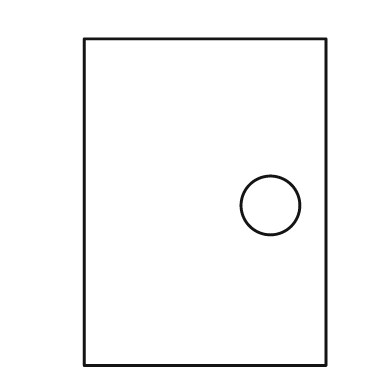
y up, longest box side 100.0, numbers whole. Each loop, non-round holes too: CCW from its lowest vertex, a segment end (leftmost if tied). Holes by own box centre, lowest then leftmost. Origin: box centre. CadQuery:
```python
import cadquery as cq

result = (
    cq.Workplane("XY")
    .moveTo(-37.0, -50.0)
    .lineTo(37.0, -50.0)
    .lineTo(37.0, 50.0)
    .lineTo(-37.0, 50.0)
    .close()
    .moveTo(20.0, -1.0)
    .circle(9.0)
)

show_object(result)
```